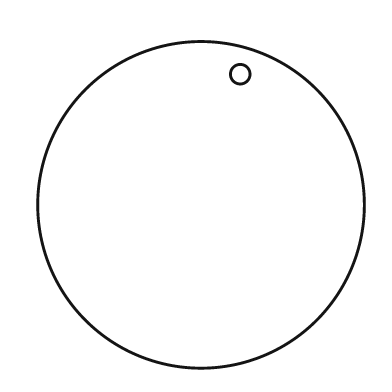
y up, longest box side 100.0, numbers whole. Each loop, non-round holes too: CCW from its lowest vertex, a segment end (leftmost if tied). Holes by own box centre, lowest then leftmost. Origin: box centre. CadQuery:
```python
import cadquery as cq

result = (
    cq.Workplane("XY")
    .moveTo(0.0, 0.0)
    .circle(50.0)
    .moveTo(12.0, 40.0)
    .circle(3.0)
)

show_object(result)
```